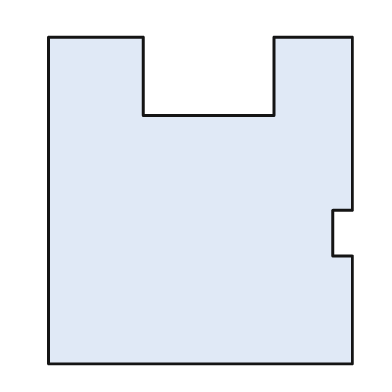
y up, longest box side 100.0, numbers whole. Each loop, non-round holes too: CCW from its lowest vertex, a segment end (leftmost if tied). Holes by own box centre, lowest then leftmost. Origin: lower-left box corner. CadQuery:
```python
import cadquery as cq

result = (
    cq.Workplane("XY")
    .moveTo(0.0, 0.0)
    .lineTo(93.0, 0.0)
    .lineTo(93.0, 33.0)
    .lineTo(87.0, 33.0)
    .lineTo(87.0, 47.0)
    .lineTo(93.0, 47.0)
    .lineTo(93.0, 100.0)
    .lineTo(69.0, 100.0)
    .lineTo(69.0, 76.0)
    .lineTo(29.0, 76.0)
    .lineTo(29.0, 100.0)
    .lineTo(0.0, 100.0)
    .close()
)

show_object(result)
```